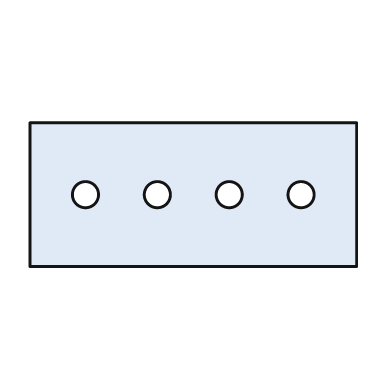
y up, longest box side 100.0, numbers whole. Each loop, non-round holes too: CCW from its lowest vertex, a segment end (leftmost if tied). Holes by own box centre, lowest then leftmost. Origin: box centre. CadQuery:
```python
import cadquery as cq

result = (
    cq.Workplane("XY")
    .moveTo(-50.0, -22.0)
    .lineTo(50.0, -22.0)
    .lineTo(50.0, 22.0)
    .lineTo(-50.0, 22.0)
    .close()
    .moveTo(-33.0, 0.0)
    .circle(4.0)
    .moveTo(-11.0, 0.0)
    .circle(4.0)
    .moveTo(11.0, 0.0)
    .circle(4.0)
    .moveTo(33.0, 0.0)
    .circle(4.0)
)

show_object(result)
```